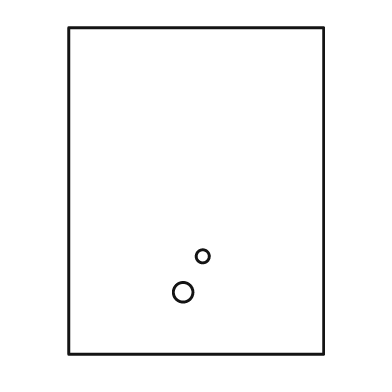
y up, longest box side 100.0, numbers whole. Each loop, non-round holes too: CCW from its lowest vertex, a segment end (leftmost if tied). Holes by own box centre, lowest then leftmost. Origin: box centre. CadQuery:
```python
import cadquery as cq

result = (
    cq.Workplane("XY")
    .moveTo(-39.0, -50.0)
    .lineTo(39.0, -50.0)
    .lineTo(39.0, 50.0)
    .lineTo(-39.0, 50.0)
    .close()
    .moveTo(-4.0, -31.0)
    .circle(3.0)
    .moveTo(2.0, -20.0)
    .circle(2.0)
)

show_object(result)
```